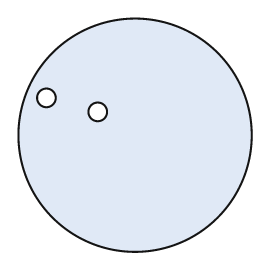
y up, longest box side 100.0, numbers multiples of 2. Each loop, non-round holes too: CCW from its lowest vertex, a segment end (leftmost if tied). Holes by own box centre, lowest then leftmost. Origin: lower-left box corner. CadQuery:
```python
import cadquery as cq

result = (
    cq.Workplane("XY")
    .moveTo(50.0, 50.0)
    .circle(50.0)
    .moveTo(34.0, 60.0)
    .circle(4.0)
    .moveTo(12.0, 66.0)
    .circle(4.0)
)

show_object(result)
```